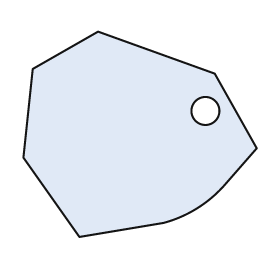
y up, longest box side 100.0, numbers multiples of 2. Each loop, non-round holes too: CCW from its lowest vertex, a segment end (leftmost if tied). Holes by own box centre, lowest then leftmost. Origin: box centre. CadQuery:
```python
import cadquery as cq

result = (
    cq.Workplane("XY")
    .moveTo(-26.0, -44.0)
    .lineTo(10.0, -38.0)
    .threePointArc((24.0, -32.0), (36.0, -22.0))
    .lineTo(50.0, -6.0)
    .lineTo(32.0, 26.0)
    .lineTo(-18.0, 44.0)
    .lineTo(-46.0, 28.0)
    .lineTo(-50.0, -10.0)
    .close()
    .moveTo(28.0, 10.0)
    .circle(6.0)
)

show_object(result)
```